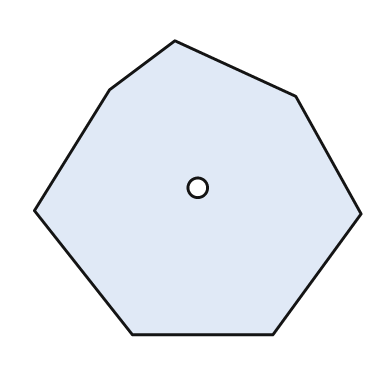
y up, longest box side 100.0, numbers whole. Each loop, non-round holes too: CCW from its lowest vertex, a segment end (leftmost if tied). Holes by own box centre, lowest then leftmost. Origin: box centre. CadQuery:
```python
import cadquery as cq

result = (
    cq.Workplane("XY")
    .moveTo(-20.0, -45.0)
    .lineTo(23.0, -45.0)
    .lineTo(50.0, -8.0)
    .lineTo(30.0, 28.0)
    .lineTo(-7.0, 45.0)
    .lineTo(-27.0, 30.0)
    .lineTo(-50.0, -7.0)
    .close()
    .moveTo(0.0, 0.0)
    .circle(3.0)
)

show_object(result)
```